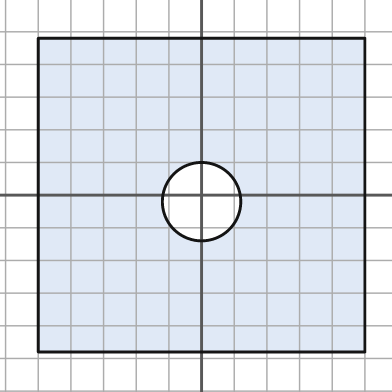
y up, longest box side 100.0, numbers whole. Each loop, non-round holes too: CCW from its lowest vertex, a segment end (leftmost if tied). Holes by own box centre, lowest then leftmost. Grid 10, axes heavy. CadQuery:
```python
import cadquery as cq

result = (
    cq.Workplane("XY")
    .moveTo(-50.0, -48.0)
    .lineTo(50.0, -48.0)
    .lineTo(50.0, 48.0)
    .lineTo(-50.0, 48.0)
    .close()
    .moveTo(0.0, -2.0)
    .circle(12.0)
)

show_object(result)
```